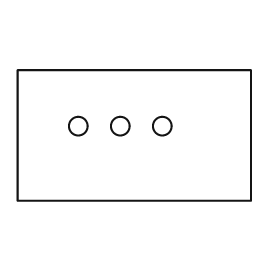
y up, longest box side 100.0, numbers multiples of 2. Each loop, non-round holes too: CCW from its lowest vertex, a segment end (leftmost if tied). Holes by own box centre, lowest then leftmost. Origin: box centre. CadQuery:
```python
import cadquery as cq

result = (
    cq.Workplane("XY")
    .moveTo(-50.0, -28.0)
    .lineTo(50.0, -28.0)
    .lineTo(50.0, 28.0)
    .lineTo(-50.0, 28.0)
    .close()
    .moveTo(-24.0, 4.0)
    .circle(4.0)
    .moveTo(-6.0, 4.0)
    .circle(4.0)
    .moveTo(12.0, 4.0)
    .circle(4.0)
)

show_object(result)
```